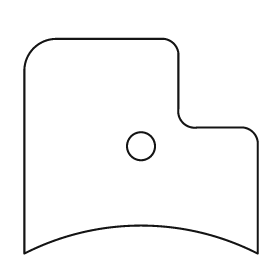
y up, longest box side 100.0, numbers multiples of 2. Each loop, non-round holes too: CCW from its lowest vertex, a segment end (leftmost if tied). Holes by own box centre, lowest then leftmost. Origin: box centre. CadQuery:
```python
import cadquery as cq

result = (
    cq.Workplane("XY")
    .moveTo(-50.0, -46.0)
    .threePointArc((0.0, -34.0), (50.0, -46.0))
    .lineTo(50.0, 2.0)
    .threePointArc((48.0, 6.0), (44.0, 8.0))
    .lineTo(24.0, 8.0)
    .threePointArc((18.0, 10.0), (16.0, 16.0))
    .lineTo(16.0, 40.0)
    .threePointArc((14.0, 44.0), (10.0, 46.0))
    .lineTo(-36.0, 46.0)
    .threePointArc((-46.0, 42.0), (-50.0, 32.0))
    .close()
    .moveTo(0.0, 0.0)
    .circle(6.0)
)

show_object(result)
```